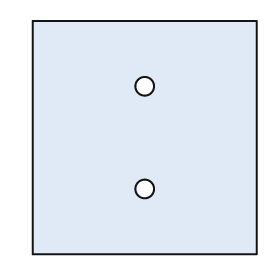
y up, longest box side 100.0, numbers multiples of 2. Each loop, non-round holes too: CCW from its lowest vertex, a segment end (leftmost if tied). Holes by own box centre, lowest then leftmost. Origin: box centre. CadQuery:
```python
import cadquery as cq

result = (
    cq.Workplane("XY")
    .moveTo(-48.0, -50.0)
    .lineTo(48.0, -50.0)
    .lineTo(48.0, 50.0)
    .lineTo(-48.0, 50.0)
    .close()
    .moveTo(0.0, -22.0)
    .circle(4.0)
    .moveTo(0.0, 22.0)
    .circle(4.0)
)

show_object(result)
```